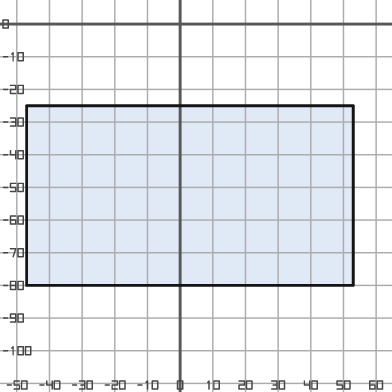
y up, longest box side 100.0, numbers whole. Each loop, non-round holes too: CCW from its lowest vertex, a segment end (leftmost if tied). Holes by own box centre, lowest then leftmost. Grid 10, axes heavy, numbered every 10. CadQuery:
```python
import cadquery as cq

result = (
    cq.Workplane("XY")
    .moveTo(-47.0, -80.0)
    .lineTo(53.0, -80.0)
    .lineTo(53.0, -25.0)
    .lineTo(-47.0, -25.0)
    .close()
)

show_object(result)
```